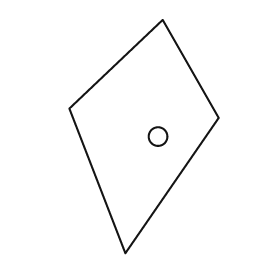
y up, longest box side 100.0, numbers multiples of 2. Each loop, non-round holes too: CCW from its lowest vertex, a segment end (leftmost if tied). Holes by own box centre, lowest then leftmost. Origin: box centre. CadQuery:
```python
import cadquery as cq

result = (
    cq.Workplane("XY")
    .moveTo(-8.0, -50.0)
    .lineTo(32.0, 8.0)
    .lineTo(8.0, 50.0)
    .lineTo(-32.0, 12.0)
    .close()
    .moveTo(6.0, 0.0)
    .circle(4.0)
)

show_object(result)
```